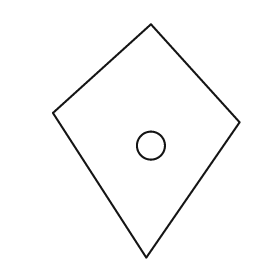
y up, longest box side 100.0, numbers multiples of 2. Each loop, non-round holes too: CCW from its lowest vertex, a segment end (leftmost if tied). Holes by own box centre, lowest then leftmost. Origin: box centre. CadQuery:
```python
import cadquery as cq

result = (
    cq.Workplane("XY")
    .moveTo(0.0, -50.0)
    .lineTo(40.0, 8.0)
    .lineTo(2.0, 50.0)
    .lineTo(-40.0, 12.0)
    .close()
    .moveTo(2.0, -2.0)
    .circle(6.0)
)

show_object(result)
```